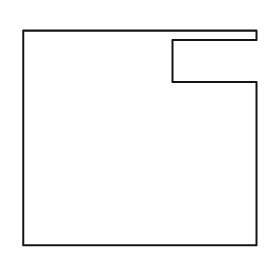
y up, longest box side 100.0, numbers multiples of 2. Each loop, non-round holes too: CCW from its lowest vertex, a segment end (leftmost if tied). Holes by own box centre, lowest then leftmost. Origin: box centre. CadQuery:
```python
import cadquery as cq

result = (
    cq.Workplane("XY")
    .moveTo(-50.0, -46.0)
    .lineTo(50.0, -46.0)
    .lineTo(50.0, 24.0)
    .lineTo(14.0, 24.0)
    .lineTo(14.0, 42.0)
    .lineTo(50.0, 42.0)
    .lineTo(50.0, 46.0)
    .lineTo(-50.0, 46.0)
    .close()
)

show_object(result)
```